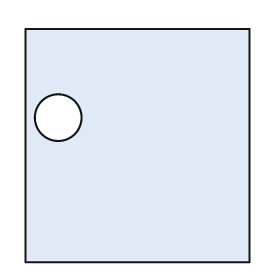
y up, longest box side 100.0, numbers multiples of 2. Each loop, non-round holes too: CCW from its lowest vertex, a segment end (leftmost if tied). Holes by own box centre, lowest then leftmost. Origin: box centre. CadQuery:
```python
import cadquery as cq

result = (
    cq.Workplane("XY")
    .moveTo(-48.0, -50.0)
    .lineTo(48.0, -50.0)
    .lineTo(48.0, 50.0)
    .lineTo(-48.0, 50.0)
    .close()
    .moveTo(-34.0, 12.0)
    .circle(10.0)
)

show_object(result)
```